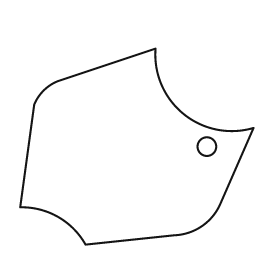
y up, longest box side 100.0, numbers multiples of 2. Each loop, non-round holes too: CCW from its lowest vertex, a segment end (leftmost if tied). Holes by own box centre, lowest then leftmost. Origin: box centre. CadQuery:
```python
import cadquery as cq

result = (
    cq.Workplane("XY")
    .moveTo(-22.0, -42.0)
    .lineTo(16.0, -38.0)
    .threePointArc((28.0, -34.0), (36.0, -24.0))
    .lineTo(50.0, 8.0)
    .threePointArc((20.0, 14.0), (8.0, 42.0))
    .lineTo(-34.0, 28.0)
    .threePointArc((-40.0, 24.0), (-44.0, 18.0))
    .lineTo(-50.0, -26.0)
    .threePointArc((-34.0, -30.0), (-22.0, -42.0))
    .close()
    .moveTo(30.0, 0.0)
    .circle(4.0)
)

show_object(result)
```